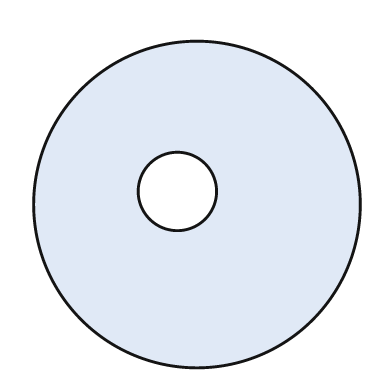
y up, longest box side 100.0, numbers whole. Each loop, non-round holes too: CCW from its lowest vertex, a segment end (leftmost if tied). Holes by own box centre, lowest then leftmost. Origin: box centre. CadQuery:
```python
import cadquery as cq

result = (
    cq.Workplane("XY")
    .moveTo(0.0, 0.0)
    .circle(50.0)
    .moveTo(-6.0, 4.0)
    .circle(12.0)
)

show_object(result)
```